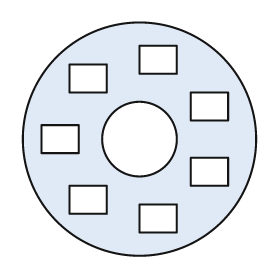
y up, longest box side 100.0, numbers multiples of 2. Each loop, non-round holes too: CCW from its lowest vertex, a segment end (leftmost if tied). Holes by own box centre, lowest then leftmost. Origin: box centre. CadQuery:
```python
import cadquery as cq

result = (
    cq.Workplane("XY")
    .moveTo(0.0, 0.0)
    .circle(50.0)
    .moveTo(0.0, -40.0)
    .lineTo(16.0, -40.0)
    .lineTo(16.0, -28.0)
    .lineTo(0.0, -28.0)
    .close()
    .moveTo(-30.0, -32.0)
    .lineTo(-14.0, -32.0)
    .lineTo(-14.0, -20.0)
    .lineTo(-30.0, -20.0)
    .close()
    .moveTo(22.0, -20.0)
    .lineTo(38.0, -20.0)
    .lineTo(38.0, -8.0)
    .lineTo(22.0, -8.0)
    .close()
    .moveTo(-42.0, -6.0)
    .lineTo(-26.0, -6.0)
    .lineTo(-26.0, 6.0)
    .lineTo(-42.0, 6.0)
    .close()
    .moveTo(0.0, 0.0)
    .circle(16.0)
    .moveTo(22.0, 8.0)
    .lineTo(38.0, 8.0)
    .lineTo(38.0, 20.0)
    .lineTo(22.0, 20.0)
    .close()
    .moveTo(-30.0, 20.0)
    .lineTo(-14.0, 20.0)
    .lineTo(-14.0, 32.0)
    .lineTo(-30.0, 32.0)
    .close()
    .moveTo(0.0, 28.0)
    .lineTo(16.0, 28.0)
    .lineTo(16.0, 40.0)
    .lineTo(0.0, 40.0)
    .close()
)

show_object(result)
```